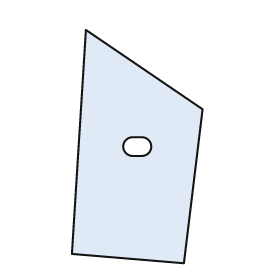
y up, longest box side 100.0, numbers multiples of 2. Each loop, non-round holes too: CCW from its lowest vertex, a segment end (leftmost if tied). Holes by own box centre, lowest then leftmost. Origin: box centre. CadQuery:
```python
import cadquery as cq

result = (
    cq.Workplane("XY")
    .moveTo(20.0, -50.0)
    .lineTo(28.0, 16.0)
    .lineTo(-22.0, 50.0)
    .lineTo(-28.0, -46.0)
    .close()
    .moveTo(-2.0, -4.0)
    .lineTo(2.0, -4.0)
    .threePointArc((6.0, 0.0), (2.0, 4.0))
    .lineTo(-2.0, 4.0)
    .threePointArc((-6.0, 0.0), (-2.0, -4.0))
    .close()
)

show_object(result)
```